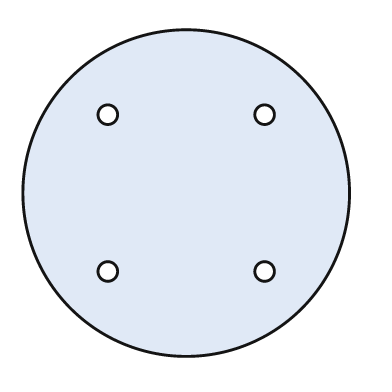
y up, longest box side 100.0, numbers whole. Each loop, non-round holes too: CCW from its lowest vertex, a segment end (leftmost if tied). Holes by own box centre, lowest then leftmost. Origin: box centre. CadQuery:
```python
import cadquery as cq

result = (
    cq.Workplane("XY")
    .moveTo(0.0, 0.0)
    .circle(50.0)
    .moveTo(-24.0, -24.0)
    .circle(3.0)
    .moveTo(24.0, -24.0)
    .circle(3.0)
    .moveTo(-24.0, 24.0)
    .circle(3.0)
    .moveTo(24.0, 24.0)
    .circle(3.0)
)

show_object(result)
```